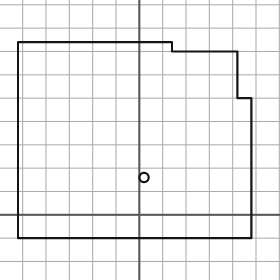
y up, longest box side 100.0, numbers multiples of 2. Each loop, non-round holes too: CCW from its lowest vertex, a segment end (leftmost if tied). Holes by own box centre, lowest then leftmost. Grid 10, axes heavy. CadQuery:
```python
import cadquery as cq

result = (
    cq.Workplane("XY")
    .moveTo(-52.0, -10.0)
    .lineTo(48.0, -10.0)
    .lineTo(48.0, 50.0)
    .lineTo(42.0, 50.0)
    .lineTo(42.0, 70.0)
    .lineTo(14.0, 70.0)
    .lineTo(14.0, 74.0)
    .lineTo(-52.0, 74.0)
    .close()
    .moveTo(2.0, 16.0)
    .circle(2.0)
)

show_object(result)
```